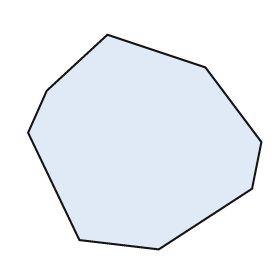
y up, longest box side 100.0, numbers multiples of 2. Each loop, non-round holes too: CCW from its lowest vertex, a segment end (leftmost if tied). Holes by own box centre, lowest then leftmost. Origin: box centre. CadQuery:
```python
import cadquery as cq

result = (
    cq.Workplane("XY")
    .moveTo(6.0, -46.0)
    .lineTo(46.0, -20.0)
    .lineTo(50.0, 0.0)
    .lineTo(26.0, 32.0)
    .lineTo(-16.0, 46.0)
    .lineTo(-42.0, 22.0)
    .lineTo(-50.0, 4.0)
    .lineTo(-28.0, -42.0)
    .close()
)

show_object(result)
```